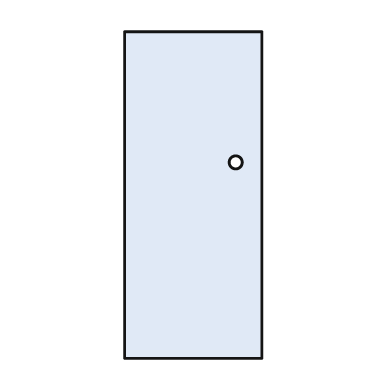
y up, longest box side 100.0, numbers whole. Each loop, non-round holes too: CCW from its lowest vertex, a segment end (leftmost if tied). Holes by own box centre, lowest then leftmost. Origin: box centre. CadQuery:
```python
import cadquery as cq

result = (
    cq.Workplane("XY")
    .moveTo(-21.0, -50.0)
    .lineTo(21.0, -50.0)
    .lineTo(21.0, 50.0)
    .lineTo(-21.0, 50.0)
    .close()
    .moveTo(13.0, 10.0)
    .circle(2.0)
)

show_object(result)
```